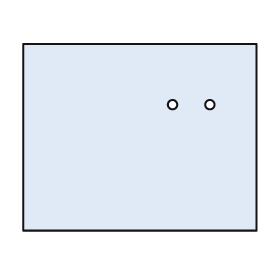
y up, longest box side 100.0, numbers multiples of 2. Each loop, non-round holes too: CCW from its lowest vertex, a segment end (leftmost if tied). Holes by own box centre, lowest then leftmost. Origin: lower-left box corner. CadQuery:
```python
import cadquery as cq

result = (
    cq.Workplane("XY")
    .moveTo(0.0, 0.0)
    .lineTo(100.0, 0.0)
    .lineTo(100.0, 80.0)
    .lineTo(0.0, 80.0)
    .close()
    .moveTo(64.0, 54.0)
    .circle(2.0)
    .moveTo(80.0, 54.0)
    .circle(2.0)
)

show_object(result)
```